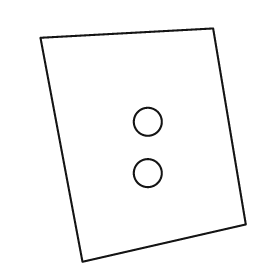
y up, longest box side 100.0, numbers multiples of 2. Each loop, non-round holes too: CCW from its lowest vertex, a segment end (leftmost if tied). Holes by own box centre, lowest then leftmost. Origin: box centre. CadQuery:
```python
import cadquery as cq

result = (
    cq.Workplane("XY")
    .moveTo(-26.0, -50.0)
    .lineTo(44.0, -34.0)
    .lineTo(30.0, 50.0)
    .lineTo(-44.0, 46.0)
    .close()
    .moveTo(2.0, -12.0)
    .circle(6.0)
    .moveTo(2.0, 10.0)
    .circle(6.0)
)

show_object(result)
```